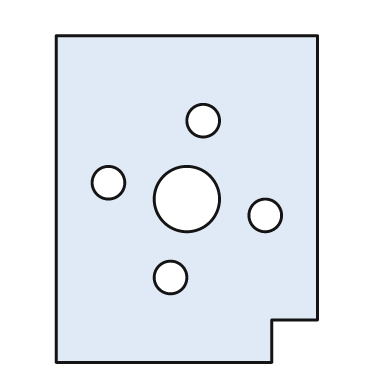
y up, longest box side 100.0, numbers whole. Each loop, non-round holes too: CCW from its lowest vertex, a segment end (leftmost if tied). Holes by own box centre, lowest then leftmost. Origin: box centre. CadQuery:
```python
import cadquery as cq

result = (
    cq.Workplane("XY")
    .moveTo(-40.0, -50.0)
    .lineTo(26.0, -50.0)
    .lineTo(26.0, -37.0)
    .lineTo(40.0, -37.0)
    .lineTo(40.0, 50.0)
    .lineTo(-40.0, 50.0)
    .close()
    .moveTo(-5.0, -24.0)
    .circle(5.0)
    .moveTo(24.0, -5.0)
    .circle(5.0)
    .moveTo(0.0, 0.0)
    .circle(10.0)
    .moveTo(-24.0, 5.0)
    .circle(5.0)
    .moveTo(5.0, 24.0)
    .circle(5.0)
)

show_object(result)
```